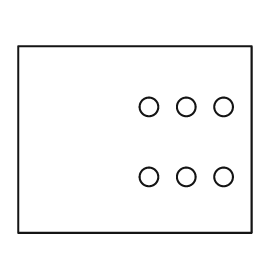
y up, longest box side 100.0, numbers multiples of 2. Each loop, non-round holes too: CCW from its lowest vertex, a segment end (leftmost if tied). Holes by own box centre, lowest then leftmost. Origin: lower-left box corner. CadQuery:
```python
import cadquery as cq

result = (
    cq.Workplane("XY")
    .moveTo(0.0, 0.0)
    .lineTo(100.0, 0.0)
    .lineTo(100.0, 80.0)
    .lineTo(0.0, 80.0)
    .close()
    .moveTo(56.0, 24.0)
    .circle(4.0)
    .moveTo(72.0, 24.0)
    .circle(4.0)
    .moveTo(88.0, 24.0)
    .circle(4.0)
    .moveTo(56.0, 54.0)
    .circle(4.0)
    .moveTo(72.0, 54.0)
    .circle(4.0)
    .moveTo(88.0, 54.0)
    .circle(4.0)
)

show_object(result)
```